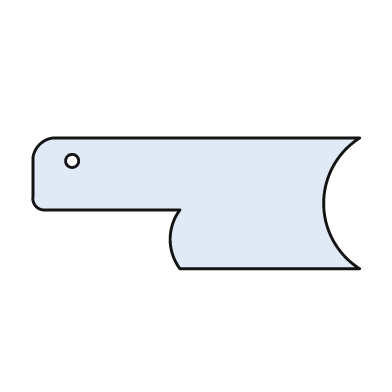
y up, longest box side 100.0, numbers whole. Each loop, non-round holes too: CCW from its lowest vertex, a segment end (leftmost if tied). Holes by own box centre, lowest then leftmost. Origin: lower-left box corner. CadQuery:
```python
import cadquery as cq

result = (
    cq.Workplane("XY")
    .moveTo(45.0, 0.0)
    .lineTo(100.0, 0.0)
    .threePointArc((89.0, 20.0), (100.0, 40.0))
    .lineTo(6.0, 40.0)
    .threePointArc((2.0, 38.0), (0.0, 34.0))
    .lineTo(0.0, 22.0)
    .threePointArc((1.0, 19.0), (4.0, 18.0))
    .lineTo(45.0, 18.0)
    .threePointArc((42.0, 9.0), (45.0, 0.0))
    .close()
    .moveTo(12.0, 33.0)
    .circle(2.0)
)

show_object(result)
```